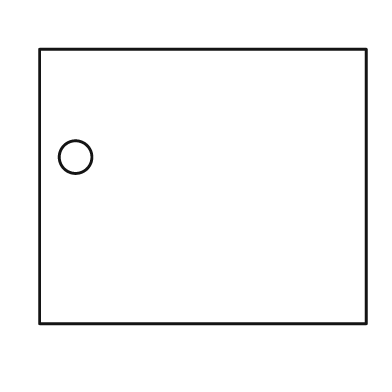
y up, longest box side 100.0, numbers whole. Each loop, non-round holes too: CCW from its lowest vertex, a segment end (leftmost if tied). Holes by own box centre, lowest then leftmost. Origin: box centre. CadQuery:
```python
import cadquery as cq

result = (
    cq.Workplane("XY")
    .moveTo(-50.0, -42.0)
    .lineTo(50.0, -42.0)
    .lineTo(50.0, 42.0)
    .lineTo(-50.0, 42.0)
    .close()
    .moveTo(-39.0, 9.0)
    .circle(5.0)
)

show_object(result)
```